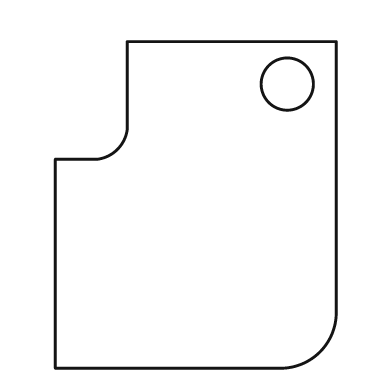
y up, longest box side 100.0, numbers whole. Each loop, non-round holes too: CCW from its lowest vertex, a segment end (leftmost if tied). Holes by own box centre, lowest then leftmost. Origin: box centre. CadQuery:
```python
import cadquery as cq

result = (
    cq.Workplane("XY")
    .moveTo(-43.0, -50.0)
    .lineTo(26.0, -50.0)
    .threePointArc((38.0, -45.0), (43.0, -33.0))
    .lineTo(43.0, 50.0)
    .lineTo(-21.0, 50.0)
    .lineTo(-21.0, 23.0)
    .threePointArc((-24.0, 17.0), (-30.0, 14.0))
    .lineTo(-43.0, 14.0)
    .close()
    .moveTo(28.0, 37.0)
    .circle(8.0)
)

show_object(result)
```